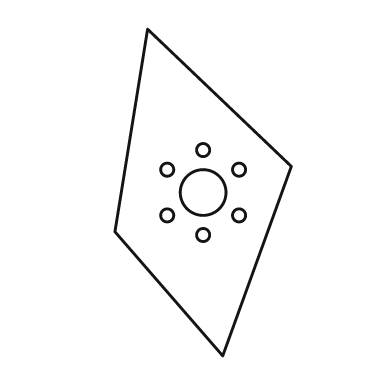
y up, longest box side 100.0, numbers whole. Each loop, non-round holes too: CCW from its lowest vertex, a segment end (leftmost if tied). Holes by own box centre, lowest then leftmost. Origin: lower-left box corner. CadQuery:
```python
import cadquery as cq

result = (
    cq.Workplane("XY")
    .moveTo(33.0, 0.0)
    .lineTo(54.0, 58.0)
    .lineTo(10.0, 100.0)
    .lineTo(0.0, 38.0)
    .close()
    .moveTo(27.0, 37.0)
    .circle(2.0)
    .moveTo(16.0, 43.0)
    .circle(2.0)
    .moveTo(38.0, 43.0)
    .circle(2.0)
    .moveTo(27.0, 50.0)
    .circle(7.0)
    .moveTo(16.0, 57.0)
    .circle(2.0)
    .moveTo(38.0, 57.0)
    .circle(2.0)
    .moveTo(27.0, 63.0)
    .circle(2.0)
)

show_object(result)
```